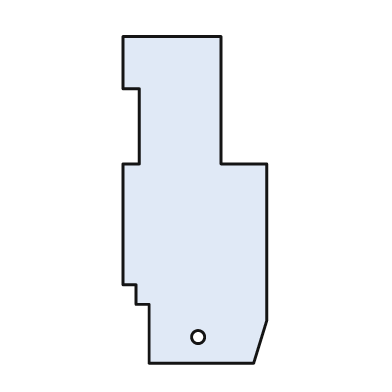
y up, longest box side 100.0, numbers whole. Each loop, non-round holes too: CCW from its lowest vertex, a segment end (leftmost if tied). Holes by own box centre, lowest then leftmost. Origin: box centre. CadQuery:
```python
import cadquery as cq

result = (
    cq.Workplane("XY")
    .moveTo(-14.0, -50.0)
    .lineTo(18.0, -50.0)
    .lineTo(22.0, -37.0)
    .lineTo(22.0, 11.0)
    .lineTo(8.0, 11.0)
    .lineTo(8.0, 50.0)
    .lineTo(-22.0, 50.0)
    .lineTo(-22.0, 34.0)
    .lineTo(-17.0, 34.0)
    .lineTo(-17.0, 11.0)
    .lineTo(-22.0, 11.0)
    .lineTo(-22.0, -26.0)
    .lineTo(-18.0, -26.0)
    .lineTo(-18.0, -32.0)
    .lineTo(-14.0, -32.0)
    .close()
    .moveTo(1.0, -42.0)
    .circle(2.0)
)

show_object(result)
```